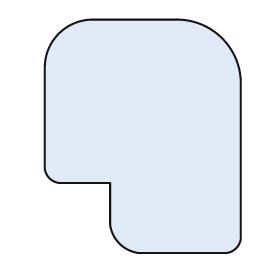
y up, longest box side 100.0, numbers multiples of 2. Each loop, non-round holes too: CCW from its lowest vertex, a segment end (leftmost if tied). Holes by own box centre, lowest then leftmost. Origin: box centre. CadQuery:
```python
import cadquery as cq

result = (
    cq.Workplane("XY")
    .moveTo(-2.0, -50.0)
    .lineTo(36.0, -50.0)
    .threePointArc((40.0, -48.0), (42.0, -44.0))
    .lineTo(42.0, 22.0)
    .threePointArc((34.0, 42.0), (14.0, 50.0))
    .lineTo(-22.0, 50.0)
    .threePointArc((-36.0, 44.0), (-42.0, 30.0))
    .lineTo(-42.0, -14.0)
    .threePointArc((-40.0, -18.0), (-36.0, -20.0))
    .lineTo(-14.0, -20.0)
    .lineTo(-14.0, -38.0)
    .threePointArc((-10.0, -46.0), (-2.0, -50.0))
    .close()
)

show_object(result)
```